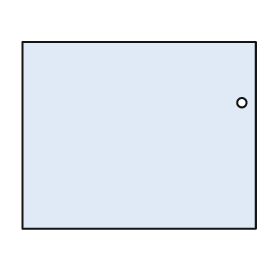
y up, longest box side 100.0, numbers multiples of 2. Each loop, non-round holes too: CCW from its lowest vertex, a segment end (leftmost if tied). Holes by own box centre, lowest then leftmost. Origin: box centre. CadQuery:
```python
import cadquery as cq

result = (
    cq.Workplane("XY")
    .moveTo(-50.0, -40.0)
    .lineTo(50.0, -40.0)
    .lineTo(50.0, 40.0)
    .lineTo(-50.0, 40.0)
    .close()
    .moveTo(44.0, 14.0)
    .circle(2.0)
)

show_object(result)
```